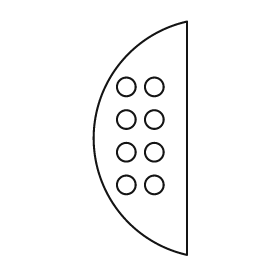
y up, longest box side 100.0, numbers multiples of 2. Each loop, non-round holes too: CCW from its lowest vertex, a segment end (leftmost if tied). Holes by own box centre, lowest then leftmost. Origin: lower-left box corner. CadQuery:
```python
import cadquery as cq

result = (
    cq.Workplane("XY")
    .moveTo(40.0, 0.0)
    .lineTo(40.0, 100.0)
    .threePointArc((0.0, 50.0), (40.0, 0.0))
    .close()
    .moveTo(14.0, 30.0)
    .circle(4.0)
    .moveTo(26.0, 30.0)
    .circle(4.0)
    .moveTo(14.0, 44.0)
    .circle(4.0)
    .moveTo(26.0, 44.0)
    .circle(4.0)
    .moveTo(14.0, 58.0)
    .circle(4.0)
    .moveTo(26.0, 58.0)
    .circle(4.0)
    .moveTo(14.0, 72.0)
    .circle(4.0)
    .moveTo(26.0, 72.0)
    .circle(4.0)
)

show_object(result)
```